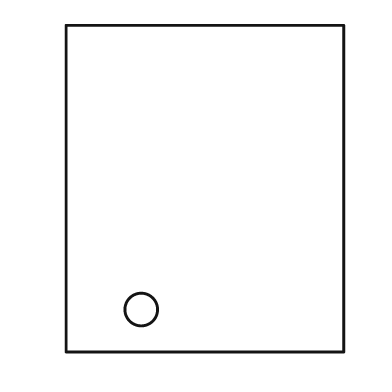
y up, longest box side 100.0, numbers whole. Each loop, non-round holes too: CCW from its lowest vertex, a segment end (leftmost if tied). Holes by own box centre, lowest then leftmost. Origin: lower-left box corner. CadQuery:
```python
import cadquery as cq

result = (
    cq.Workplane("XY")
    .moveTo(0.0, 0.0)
    .lineTo(85.0, 0.0)
    .lineTo(85.0, 100.0)
    .lineTo(0.0, 100.0)
    .close()
    .moveTo(23.0, 13.0)
    .circle(5.0)
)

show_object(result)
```